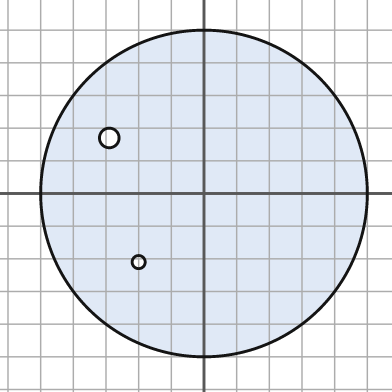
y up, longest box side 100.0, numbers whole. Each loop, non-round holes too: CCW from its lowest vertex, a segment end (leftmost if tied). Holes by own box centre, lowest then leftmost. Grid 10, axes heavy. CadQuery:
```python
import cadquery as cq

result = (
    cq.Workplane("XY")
    .moveTo(0.0, 0.0)
    .circle(50.0)
    .moveTo(-20.0, -21.0)
    .circle(2.0)
    .moveTo(-29.0, 17.0)
    .circle(3.0)
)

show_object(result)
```